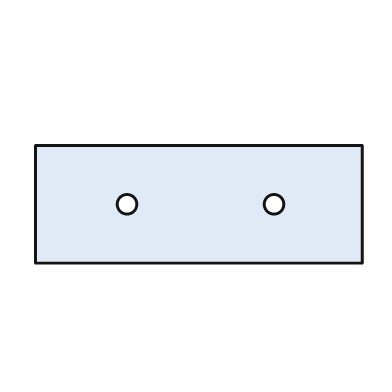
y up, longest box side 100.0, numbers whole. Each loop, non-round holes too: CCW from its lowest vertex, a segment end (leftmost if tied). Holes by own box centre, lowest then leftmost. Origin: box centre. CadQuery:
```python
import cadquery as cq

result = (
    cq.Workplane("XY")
    .moveTo(-50.0, -18.0)
    .lineTo(50.0, -18.0)
    .lineTo(50.0, 18.0)
    .lineTo(-50.0, 18.0)
    .close()
    .moveTo(-22.0, 0.0)
    .circle(3.0)
    .moveTo(23.0, 0.0)
    .circle(3.0)
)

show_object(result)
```